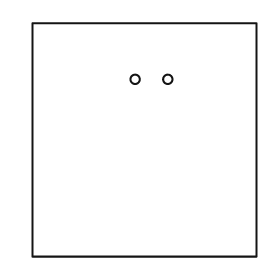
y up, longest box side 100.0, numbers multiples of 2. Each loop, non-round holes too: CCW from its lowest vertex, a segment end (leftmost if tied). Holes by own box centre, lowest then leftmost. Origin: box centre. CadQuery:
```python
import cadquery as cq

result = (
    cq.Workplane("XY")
    .moveTo(-48.0, -50.0)
    .lineTo(48.0, -50.0)
    .lineTo(48.0, 50.0)
    .lineTo(-48.0, 50.0)
    .close()
    .moveTo(-4.0, 26.0)
    .circle(2.0)
    .moveTo(10.0, 26.0)
    .circle(2.0)
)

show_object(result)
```